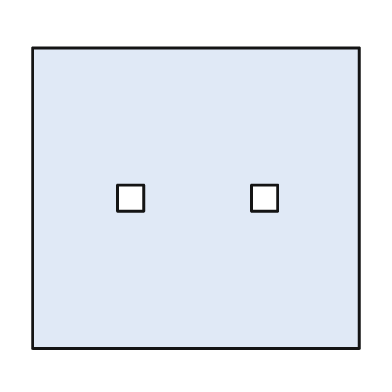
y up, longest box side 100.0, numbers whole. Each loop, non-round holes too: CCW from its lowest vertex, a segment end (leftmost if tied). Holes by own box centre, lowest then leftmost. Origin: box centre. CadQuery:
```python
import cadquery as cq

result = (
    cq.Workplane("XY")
    .moveTo(-50.0, -46.0)
    .lineTo(50.0, -46.0)
    .lineTo(50.0, 46.0)
    .lineTo(-50.0, 46.0)
    .close()
    .moveTo(-24.0, -4.0)
    .lineTo(-16.0, -4.0)
    .lineTo(-16.0, 4.0)
    .lineTo(-24.0, 4.0)
    .close()
    .moveTo(17.0, -4.0)
    .lineTo(25.0, -4.0)
    .lineTo(25.0, 4.0)
    .lineTo(17.0, 4.0)
    .close()
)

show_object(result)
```